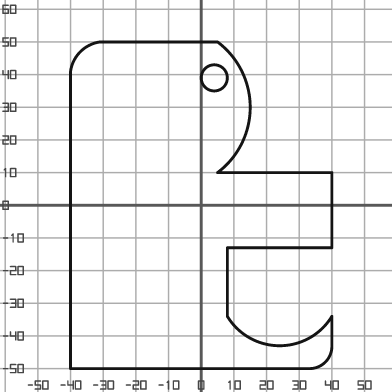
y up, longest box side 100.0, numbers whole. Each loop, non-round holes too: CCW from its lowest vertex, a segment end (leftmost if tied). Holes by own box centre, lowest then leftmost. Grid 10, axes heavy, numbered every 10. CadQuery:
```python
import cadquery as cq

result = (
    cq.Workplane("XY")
    .moveTo(-40.0, -50.0)
    .lineTo(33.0, -50.0)
    .threePointArc((38.0, -48.0), (40.0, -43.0))
    .lineTo(40.0, -34.0)
    .threePointArc((24.0, -43.0), (8.0, -34.0))
    .lineTo(8.0, -13.0)
    .lineTo(40.0, -13.0)
    .lineTo(40.0, 10.0)
    .lineTo(5.0, 10.0)
    .threePointArc((15.0, 30.0), (5.0, 50.0))
    .lineTo(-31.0, 50.0)
    .threePointArc((-37.0, 47.0), (-40.0, 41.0))
    .close()
    .moveTo(4.0, 39.0)
    .circle(4.0)
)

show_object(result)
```